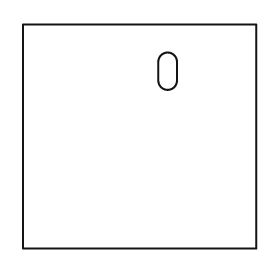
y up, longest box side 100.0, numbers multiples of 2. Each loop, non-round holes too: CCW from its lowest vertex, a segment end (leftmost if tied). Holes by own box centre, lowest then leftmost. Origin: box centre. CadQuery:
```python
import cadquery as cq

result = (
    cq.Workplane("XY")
    .moveTo(-50.0, -48.0)
    .lineTo(50.0, -48.0)
    .lineTo(50.0, 48.0)
    .lineTo(-50.0, 48.0)
    .close()
    .moveTo(8.0, 24.0)
    .threePointArc((12.0, 20.0), (16.0, 24.0))
    .lineTo(16.0, 32.0)
    .threePointArc((12.0, 36.0), (8.0, 32.0))
    .close()
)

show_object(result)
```